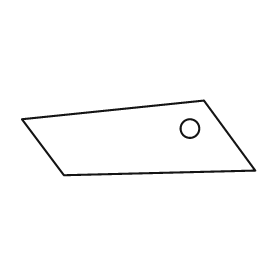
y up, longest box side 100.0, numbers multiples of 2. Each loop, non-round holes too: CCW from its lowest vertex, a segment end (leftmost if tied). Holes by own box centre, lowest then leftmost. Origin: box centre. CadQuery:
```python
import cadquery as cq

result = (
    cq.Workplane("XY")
    .moveTo(-32.0, -16.0)
    .lineTo(50.0, -14.0)
    .lineTo(28.0, 16.0)
    .lineTo(-50.0, 8.0)
    .close()
    .moveTo(22.0, 4.0)
    .circle(4.0)
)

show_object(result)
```